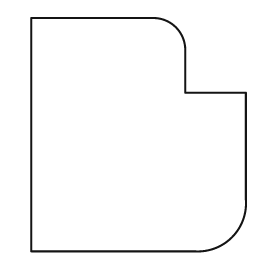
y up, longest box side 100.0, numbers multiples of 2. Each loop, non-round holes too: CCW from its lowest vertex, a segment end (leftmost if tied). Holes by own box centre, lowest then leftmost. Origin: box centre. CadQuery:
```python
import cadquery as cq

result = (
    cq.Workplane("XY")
    .moveTo(-46.0, -50.0)
    .lineTo(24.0, -50.0)
    .threePointArc((40.0, -44.0), (46.0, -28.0))
    .lineTo(46.0, 18.0)
    .lineTo(20.0, 18.0)
    .lineTo(20.0, 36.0)
    .threePointArc((16.0, 46.0), (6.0, 50.0))
    .lineTo(-46.0, 50.0)
    .close()
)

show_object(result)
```